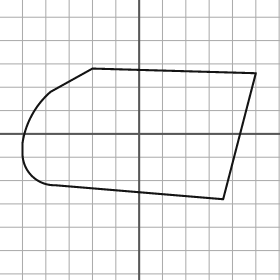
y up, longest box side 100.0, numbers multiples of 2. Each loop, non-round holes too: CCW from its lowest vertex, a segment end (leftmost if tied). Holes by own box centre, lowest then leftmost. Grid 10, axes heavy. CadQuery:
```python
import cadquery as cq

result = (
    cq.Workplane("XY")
    .moveTo(36.0, -28.0)
    .lineTo(50.0, 26.0)
    .lineTo(-20.0, 28.0)
    .lineTo(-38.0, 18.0)
    .threePointArc((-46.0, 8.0), (-50.0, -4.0))
    .lineTo(-50.0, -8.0)
    .threePointArc((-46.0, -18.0), (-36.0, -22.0))
    .close()
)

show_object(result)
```